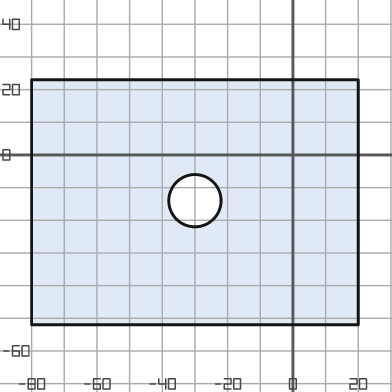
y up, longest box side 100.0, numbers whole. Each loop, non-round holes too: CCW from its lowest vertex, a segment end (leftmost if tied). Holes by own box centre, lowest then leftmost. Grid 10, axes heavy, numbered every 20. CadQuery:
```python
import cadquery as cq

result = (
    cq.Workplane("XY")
    .moveTo(-80.0, -52.0)
    .lineTo(20.0, -52.0)
    .lineTo(20.0, 23.0)
    .lineTo(-80.0, 23.0)
    .close()
    .moveTo(-30.0, -14.0)
    .circle(8.0)
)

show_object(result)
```